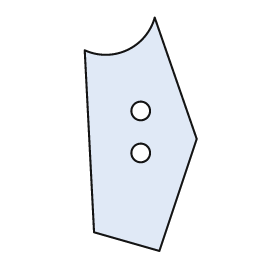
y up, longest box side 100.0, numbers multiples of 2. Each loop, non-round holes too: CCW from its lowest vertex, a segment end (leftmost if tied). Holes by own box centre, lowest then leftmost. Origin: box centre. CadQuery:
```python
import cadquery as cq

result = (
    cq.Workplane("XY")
    .moveTo(8.0, -50.0)
    .lineTo(24.0, -2.0)
    .lineTo(6.0, 50.0)
    .threePointArc((-6.0, 36.0), (-24.0, 36.0))
    .lineTo(-20.0, -42.0)
    .close()
    .moveTo(0.0, -8.0)
    .circle(4.0)
    .moveTo(0.0, 10.0)
    .circle(4.0)
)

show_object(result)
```